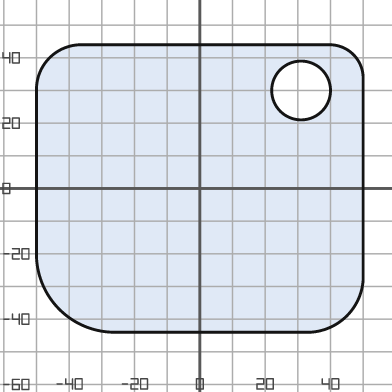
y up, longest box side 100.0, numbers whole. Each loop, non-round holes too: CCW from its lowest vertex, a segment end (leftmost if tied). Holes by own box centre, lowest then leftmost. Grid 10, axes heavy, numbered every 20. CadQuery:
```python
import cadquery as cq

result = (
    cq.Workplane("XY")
    .moveTo(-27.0, -44.0)
    .lineTo(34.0, -44.0)
    .threePointArc((45.0, -39.0), (50.0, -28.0))
    .lineTo(50.0, 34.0)
    .threePointArc((47.0, 41.0), (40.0, 44.0))
    .lineTo(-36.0, 44.0)
    .threePointArc((-46.0, 40.0), (-50.0, 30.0))
    .lineTo(-50.0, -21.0)
    .threePointArc((-43.0, -37.0), (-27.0, -44.0))
    .close()
    .moveTo(31.0, 30.0)
    .circle(9.0)
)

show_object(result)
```